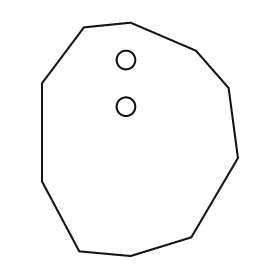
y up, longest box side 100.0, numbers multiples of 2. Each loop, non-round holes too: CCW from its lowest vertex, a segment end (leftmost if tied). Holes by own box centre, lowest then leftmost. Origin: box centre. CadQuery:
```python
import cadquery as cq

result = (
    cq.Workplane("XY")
    .moveTo(-4.0, -50.0)
    .lineTo(22.0, -42.0)
    .lineTo(42.0, -8.0)
    .lineTo(38.0, 22.0)
    .lineTo(24.0, 38.0)
    .lineTo(-4.0, 50.0)
    .lineTo(-24.0, 48.0)
    .lineTo(-42.0, 24.0)
    .lineTo(-42.0, -18.0)
    .lineTo(-26.0, -48.0)
    .close()
    .moveTo(-6.0, 14.0)
    .circle(4.0)
    .moveTo(-6.0, 34.0)
    .circle(4.0)
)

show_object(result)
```